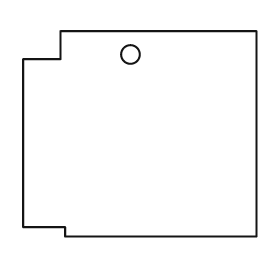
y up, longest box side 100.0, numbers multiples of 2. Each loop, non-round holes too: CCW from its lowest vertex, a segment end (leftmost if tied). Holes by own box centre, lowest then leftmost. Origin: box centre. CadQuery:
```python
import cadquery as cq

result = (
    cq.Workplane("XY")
    .moveTo(-32.0, -44.0)
    .lineTo(50.0, -44.0)
    .lineTo(50.0, 44.0)
    .lineTo(-34.0, 44.0)
    .lineTo(-34.0, 32.0)
    .lineTo(-50.0, 32.0)
    .lineTo(-50.0, -40.0)
    .lineTo(-32.0, -40.0)
    .close()
    .moveTo(-4.0, 34.0)
    .circle(4.0)
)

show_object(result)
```